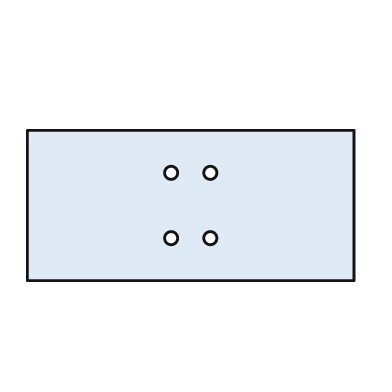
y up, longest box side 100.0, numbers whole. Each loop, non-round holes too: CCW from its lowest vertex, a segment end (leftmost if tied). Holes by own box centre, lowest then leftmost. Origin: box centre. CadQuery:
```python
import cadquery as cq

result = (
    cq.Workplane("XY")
    .moveTo(-50.0, -23.0)
    .lineTo(50.0, -23.0)
    .lineTo(50.0, 23.0)
    .lineTo(-50.0, 23.0)
    .close()
    .moveTo(-6.0, -10.0)
    .circle(2.0)
    .moveTo(6.0, -10.0)
    .circle(2.0)
    .moveTo(-6.0, 10.0)
    .circle(2.0)
    .moveTo(6.0, 10.0)
    .circle(2.0)
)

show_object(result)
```